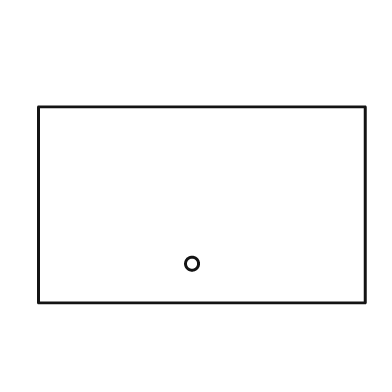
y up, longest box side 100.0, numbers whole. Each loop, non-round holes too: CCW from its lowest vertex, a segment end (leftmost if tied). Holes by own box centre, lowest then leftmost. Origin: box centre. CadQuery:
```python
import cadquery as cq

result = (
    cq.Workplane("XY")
    .moveTo(-50.0, -30.0)
    .lineTo(50.0, -30.0)
    .lineTo(50.0, 30.0)
    .lineTo(-50.0, 30.0)
    .close()
    .moveTo(-3.0, -18.0)
    .circle(2.0)
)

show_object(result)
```